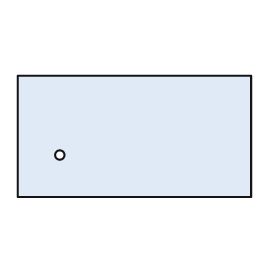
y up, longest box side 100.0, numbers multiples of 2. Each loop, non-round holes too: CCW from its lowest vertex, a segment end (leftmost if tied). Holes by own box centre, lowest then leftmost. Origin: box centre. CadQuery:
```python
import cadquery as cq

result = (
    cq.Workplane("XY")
    .moveTo(-50.0, -26.0)
    .lineTo(50.0, -26.0)
    .lineTo(50.0, 26.0)
    .lineTo(-50.0, 26.0)
    .close()
    .moveTo(-32.0, -8.0)
    .circle(2.0)
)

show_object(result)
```